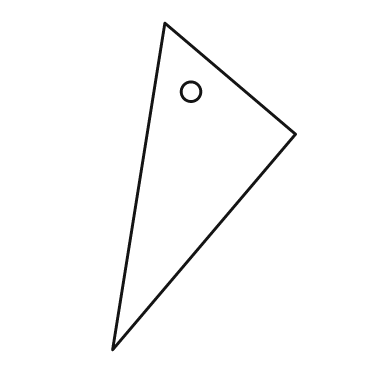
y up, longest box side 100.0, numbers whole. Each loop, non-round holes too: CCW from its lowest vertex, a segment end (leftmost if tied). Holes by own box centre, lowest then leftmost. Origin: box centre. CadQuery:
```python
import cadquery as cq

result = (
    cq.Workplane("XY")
    .moveTo(-28.0, -50.0)
    .lineTo(28.0, 16.0)
    .lineTo(-12.0, 50.0)
    .close()
    .moveTo(-4.0, 29.0)
    .circle(3.0)
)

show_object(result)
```